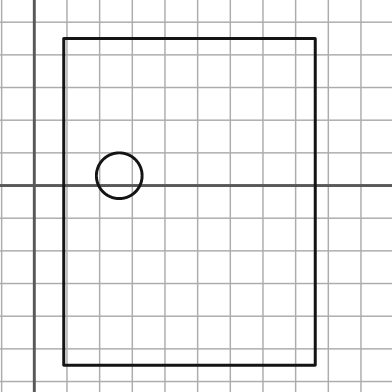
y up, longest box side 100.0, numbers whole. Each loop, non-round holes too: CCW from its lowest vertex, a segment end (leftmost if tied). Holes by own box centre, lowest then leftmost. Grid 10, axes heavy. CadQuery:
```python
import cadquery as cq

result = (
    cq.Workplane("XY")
    .moveTo(9.0, -55.0)
    .lineTo(86.0, -55.0)
    .lineTo(86.0, 45.0)
    .lineTo(9.0, 45.0)
    .close()
    .moveTo(26.0, 3.0)
    .circle(7.0)
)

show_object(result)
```